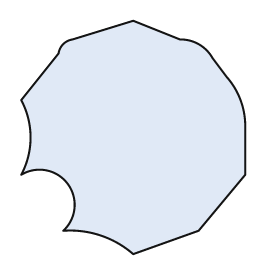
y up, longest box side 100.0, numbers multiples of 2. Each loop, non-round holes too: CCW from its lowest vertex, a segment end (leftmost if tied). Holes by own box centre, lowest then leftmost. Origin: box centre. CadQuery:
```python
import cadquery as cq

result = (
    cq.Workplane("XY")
    .moveTo(0.0, -50.0)
    .lineTo(28.0, -40.0)
    .lineTo(48.0, -16.0)
    .lineTo(48.0, 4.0)
    .threePointArc((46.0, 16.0), (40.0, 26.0))
    .lineTo(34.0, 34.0)
    .threePointArc((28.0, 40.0), (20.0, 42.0))
    .lineTo(0.0, 50.0)
    .lineTo(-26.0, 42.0)
    .threePointArc((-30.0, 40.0), (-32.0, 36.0))
    .lineTo(-48.0, 16.0)
    .threePointArc((-44.0, 0.0), (-48.0, -16.0))
    .threePointArc((-28.0, -20.0), (-30.0, -40.0))
    .threePointArc((-14.0, -42.0), (0.0, -50.0))
    .close()
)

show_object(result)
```